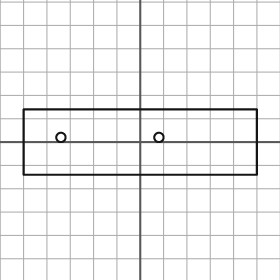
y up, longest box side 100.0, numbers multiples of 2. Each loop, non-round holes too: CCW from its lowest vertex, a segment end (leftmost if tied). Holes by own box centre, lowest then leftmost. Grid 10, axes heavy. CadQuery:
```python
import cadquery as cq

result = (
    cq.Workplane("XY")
    .moveTo(-50.0, -14.0)
    .lineTo(50.0, -14.0)
    .lineTo(50.0, 14.0)
    .lineTo(-50.0, 14.0)
    .close()
    .moveTo(-34.0, 2.0)
    .circle(2.0)
    .moveTo(8.0, 2.0)
    .circle(2.0)
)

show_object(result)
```